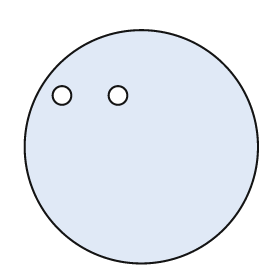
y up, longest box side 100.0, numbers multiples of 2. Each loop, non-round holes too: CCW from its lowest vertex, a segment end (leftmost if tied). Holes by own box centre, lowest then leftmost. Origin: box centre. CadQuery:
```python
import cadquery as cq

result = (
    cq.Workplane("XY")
    .moveTo(0.0, 0.0)
    .circle(50.0)
    .moveTo(-34.0, 22.0)
    .circle(4.0)
    .moveTo(-10.0, 22.0)
    .circle(4.0)
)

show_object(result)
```